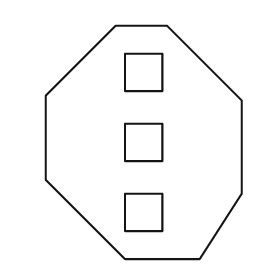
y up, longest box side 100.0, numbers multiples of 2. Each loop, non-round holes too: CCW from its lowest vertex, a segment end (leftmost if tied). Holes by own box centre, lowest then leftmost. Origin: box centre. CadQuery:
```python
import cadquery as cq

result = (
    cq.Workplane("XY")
    .moveTo(-8.0, -50.0)
    .lineTo(24.0, -50.0)
    .lineTo(42.0, -22.0)
    .lineTo(42.0, 18.0)
    .lineTo(10.0, 50.0)
    .lineTo(-12.0, 50.0)
    .lineTo(-42.0, 20.0)
    .lineTo(-42.0, -16.0)
    .close()
    .moveTo(-8.0, -38.0)
    .lineTo(8.0, -38.0)
    .lineTo(8.0, -22.0)
    .lineTo(-8.0, -22.0)
    .close()
    .moveTo(-8.0, -8.0)
    .lineTo(8.0, -8.0)
    .lineTo(8.0, 8.0)
    .lineTo(-8.0, 8.0)
    .close()
    .moveTo(-8.0, 22.0)
    .lineTo(8.0, 22.0)
    .lineTo(8.0, 38.0)
    .lineTo(-8.0, 38.0)
    .close()
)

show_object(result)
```